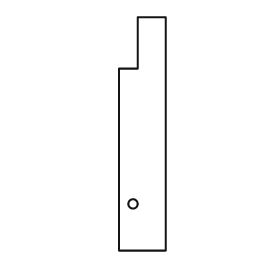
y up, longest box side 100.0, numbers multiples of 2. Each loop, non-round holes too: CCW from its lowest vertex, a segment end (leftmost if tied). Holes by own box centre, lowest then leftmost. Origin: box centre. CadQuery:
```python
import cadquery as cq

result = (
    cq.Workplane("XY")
    .moveTo(-10.0, -50.0)
    .lineTo(10.0, -50.0)
    .lineTo(10.0, 50.0)
    .lineTo(-2.0, 50.0)
    .lineTo(-2.0, 28.0)
    .lineTo(-10.0, 28.0)
    .close()
    .moveTo(-4.0, -30.0)
    .circle(2.0)
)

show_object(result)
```